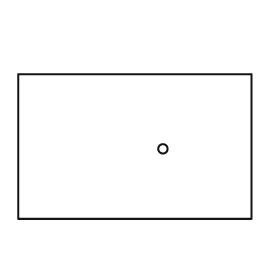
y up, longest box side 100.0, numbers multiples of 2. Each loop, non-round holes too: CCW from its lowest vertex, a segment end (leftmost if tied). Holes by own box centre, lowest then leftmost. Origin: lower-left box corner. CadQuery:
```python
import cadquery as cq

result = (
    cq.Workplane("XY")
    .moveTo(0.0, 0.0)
    .lineTo(100.0, 0.0)
    .lineTo(100.0, 62.0)
    .lineTo(0.0, 62.0)
    .close()
    .moveTo(62.0, 30.0)
    .circle(2.0)
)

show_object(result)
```